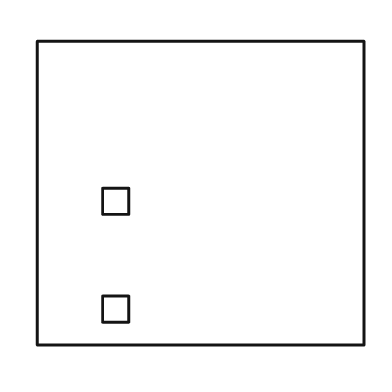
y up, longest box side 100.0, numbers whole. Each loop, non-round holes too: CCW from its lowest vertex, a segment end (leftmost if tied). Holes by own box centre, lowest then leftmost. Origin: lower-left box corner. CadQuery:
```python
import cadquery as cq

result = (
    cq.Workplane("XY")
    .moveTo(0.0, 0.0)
    .lineTo(100.0, 0.0)
    .lineTo(100.0, 93.0)
    .lineTo(0.0, 93.0)
    .close()
    .moveTo(20.0, 7.0)
    .lineTo(28.0, 7.0)
    .lineTo(28.0, 15.0)
    .lineTo(20.0, 15.0)
    .close()
    .moveTo(20.0, 40.0)
    .lineTo(28.0, 40.0)
    .lineTo(28.0, 48.0)
    .lineTo(20.0, 48.0)
    .close()
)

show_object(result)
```